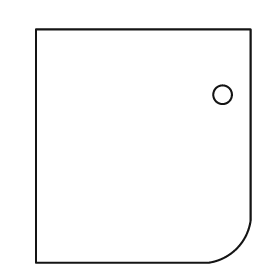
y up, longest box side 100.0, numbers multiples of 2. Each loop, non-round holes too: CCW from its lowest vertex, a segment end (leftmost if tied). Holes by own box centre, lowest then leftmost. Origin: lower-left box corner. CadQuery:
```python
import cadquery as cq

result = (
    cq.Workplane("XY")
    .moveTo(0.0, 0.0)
    .lineTo(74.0, 0.0)
    .threePointArc((86.0, 6.0), (92.0, 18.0))
    .lineTo(92.0, 100.0)
    .lineTo(0.0, 100.0)
    .close()
    .moveTo(80.0, 72.0)
    .circle(4.0)
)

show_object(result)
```